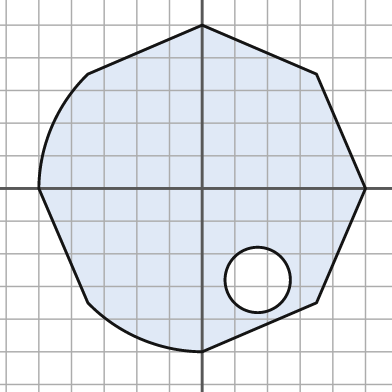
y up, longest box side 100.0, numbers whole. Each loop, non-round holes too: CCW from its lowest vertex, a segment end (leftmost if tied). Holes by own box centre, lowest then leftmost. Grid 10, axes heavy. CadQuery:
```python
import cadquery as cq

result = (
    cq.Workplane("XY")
    .moveTo(0.0, -50.0)
    .lineTo(35.0, -35.0)
    .lineTo(50.0, 0.0)
    .lineTo(35.0, 35.0)
    .lineTo(0.0, 50.0)
    .lineTo(-35.0, 35.0)
    .threePointArc((-46.0, 19.0), (-50.0, 0.0))
    .lineTo(-35.0, -35.0)
    .threePointArc((-19.0, -46.0), (0.0, -50.0))
    .close()
    .moveTo(17.0, -28.0)
    .circle(10.0)
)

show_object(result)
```